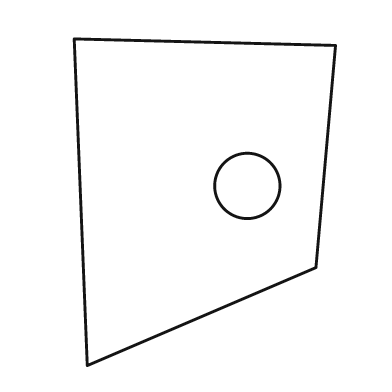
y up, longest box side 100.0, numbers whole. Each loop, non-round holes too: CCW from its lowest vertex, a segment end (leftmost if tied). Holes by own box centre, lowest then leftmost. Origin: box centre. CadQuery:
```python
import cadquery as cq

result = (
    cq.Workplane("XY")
    .moveTo(-36.0, -50.0)
    .lineTo(34.0, -20.0)
    .lineTo(40.0, 48.0)
    .lineTo(-40.0, 50.0)
    .close()
    .moveTo(13.0, 5.0)
    .circle(10.0)
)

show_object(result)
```